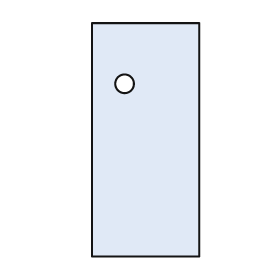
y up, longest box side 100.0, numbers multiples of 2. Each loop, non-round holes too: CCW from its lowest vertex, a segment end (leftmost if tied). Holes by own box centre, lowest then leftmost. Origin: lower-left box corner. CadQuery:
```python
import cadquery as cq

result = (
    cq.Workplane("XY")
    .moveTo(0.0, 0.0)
    .lineTo(46.0, 0.0)
    .lineTo(46.0, 100.0)
    .lineTo(0.0, 100.0)
    .close()
    .moveTo(14.0, 74.0)
    .circle(4.0)
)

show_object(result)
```